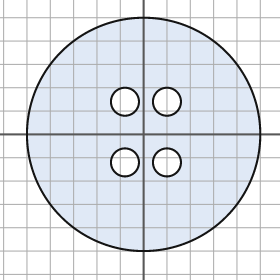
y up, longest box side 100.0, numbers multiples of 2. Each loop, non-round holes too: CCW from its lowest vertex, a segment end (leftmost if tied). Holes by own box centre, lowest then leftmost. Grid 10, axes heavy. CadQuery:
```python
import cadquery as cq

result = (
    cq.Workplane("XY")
    .moveTo(0.0, 0.0)
    .circle(50.0)
    .moveTo(-8.0, -12.0)
    .circle(6.0)
    .moveTo(10.0, -12.0)
    .circle(6.0)
    .moveTo(-8.0, 14.0)
    .circle(6.0)
    .moveTo(10.0, 14.0)
    .circle(6.0)
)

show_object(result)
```